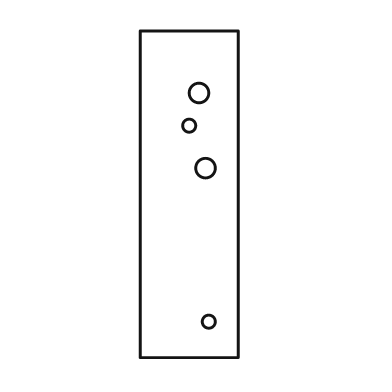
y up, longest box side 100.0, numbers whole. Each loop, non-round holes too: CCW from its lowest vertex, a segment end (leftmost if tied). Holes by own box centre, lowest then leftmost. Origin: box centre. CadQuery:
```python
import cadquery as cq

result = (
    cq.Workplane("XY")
    .moveTo(-15.0, -50.0)
    .lineTo(15.0, -50.0)
    .lineTo(15.0, 50.0)
    .lineTo(-15.0, 50.0)
    .close()
    .moveTo(6.0, -39.0)
    .circle(2.0)
    .moveTo(5.0, 8.0)
    .circle(3.0)
    .moveTo(0.0, 21.0)
    .circle(2.0)
    .moveTo(3.0, 31.0)
    .circle(3.0)
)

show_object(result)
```